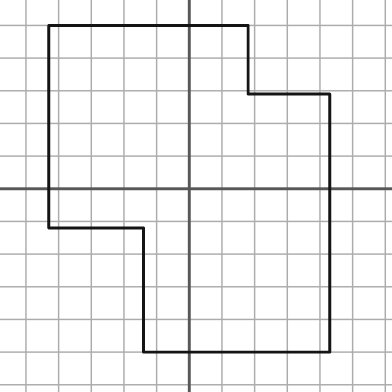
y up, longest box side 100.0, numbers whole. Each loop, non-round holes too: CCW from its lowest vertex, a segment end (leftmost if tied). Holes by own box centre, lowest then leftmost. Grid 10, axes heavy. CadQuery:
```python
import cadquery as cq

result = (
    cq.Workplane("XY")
    .moveTo(-14.0, -50.0)
    .lineTo(43.0, -50.0)
    .lineTo(43.0, 29.0)
    .lineTo(18.0, 29.0)
    .lineTo(18.0, 50.0)
    .lineTo(-43.0, 50.0)
    .lineTo(-43.0, -12.0)
    .lineTo(-14.0, -12.0)
    .close()
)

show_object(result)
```